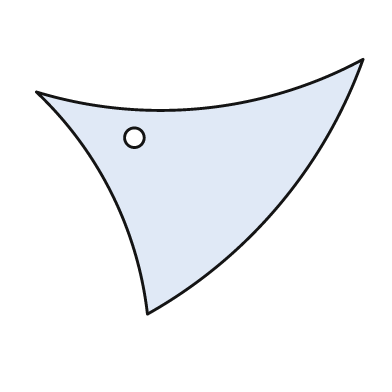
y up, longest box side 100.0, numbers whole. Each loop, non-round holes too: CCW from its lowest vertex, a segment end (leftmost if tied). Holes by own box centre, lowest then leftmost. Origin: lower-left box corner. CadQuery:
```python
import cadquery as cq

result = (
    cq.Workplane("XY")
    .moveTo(34.0, 0.0)
    .threePointArc((74.0, 33.0), (100.0, 78.0))
    .threePointArc((51.0, 63.0), (0.0, 68.0))
    .threePointArc((23.0, 37.0), (34.0, 0.0))
    .close()
    .moveTo(30.0, 54.0)
    .circle(3.0)
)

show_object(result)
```